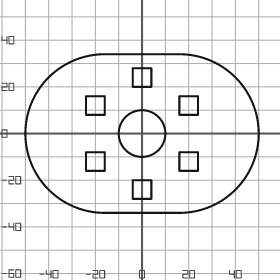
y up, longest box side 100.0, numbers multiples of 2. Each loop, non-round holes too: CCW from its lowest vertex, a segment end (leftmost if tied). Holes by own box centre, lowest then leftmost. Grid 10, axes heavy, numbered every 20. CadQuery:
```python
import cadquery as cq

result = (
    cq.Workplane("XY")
    .moveTo(-16.0, -34.0)
    .lineTo(16.0, -34.0)
    .threePointArc((50.0, 0.0), (16.0, 34.0))
    .lineTo(-16.0, 34.0)
    .threePointArc((-50.0, 0.0), (-16.0, -34.0))
    .close()
    .moveTo(-4.0, -28.0)
    .lineTo(4.0, -28.0)
    .lineTo(4.0, -20.0)
    .lineTo(-4.0, -20.0)
    .close()
    .moveTo(-24.0, -16.0)
    .lineTo(-16.0, -16.0)
    .lineTo(-16.0, -8.0)
    .lineTo(-24.0, -8.0)
    .close()
    .moveTo(16.0, -16.0)
    .lineTo(24.0, -16.0)
    .lineTo(24.0, -8.0)
    .lineTo(16.0, -8.0)
    .close()
    .moveTo(0.0, 0.0)
    .circle(10.0)
    .moveTo(-24.0, 8.0)
    .lineTo(-16.0, 8.0)
    .lineTo(-16.0, 16.0)
    .lineTo(-24.0, 16.0)
    .close()
    .moveTo(16.0, 8.0)
    .lineTo(24.0, 8.0)
    .lineTo(24.0, 16.0)
    .lineTo(16.0, 16.0)
    .close()
    .moveTo(-4.0, 20.0)
    .lineTo(4.0, 20.0)
    .lineTo(4.0, 28.0)
    .lineTo(-4.0, 28.0)
    .close()
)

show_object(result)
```